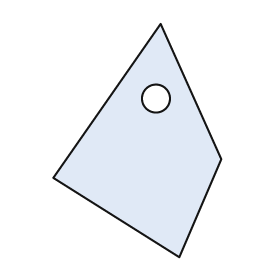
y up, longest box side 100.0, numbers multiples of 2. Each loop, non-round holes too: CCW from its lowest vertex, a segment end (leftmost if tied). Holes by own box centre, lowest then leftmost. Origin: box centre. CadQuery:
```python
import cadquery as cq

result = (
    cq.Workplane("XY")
    .moveTo(18.0, -50.0)
    .lineTo(36.0, -8.0)
    .lineTo(10.0, 50.0)
    .lineTo(-36.0, -16.0)
    .close()
    .moveTo(8.0, 18.0)
    .circle(6.0)
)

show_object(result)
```